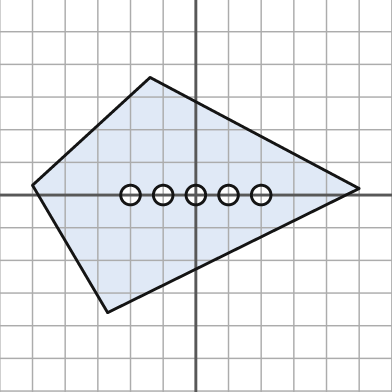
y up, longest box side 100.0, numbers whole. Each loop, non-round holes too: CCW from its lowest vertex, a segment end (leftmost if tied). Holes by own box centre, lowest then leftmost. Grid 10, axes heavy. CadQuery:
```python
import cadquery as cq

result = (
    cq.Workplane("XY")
    .moveTo(-27.0, -36.0)
    .lineTo(50.0, 2.0)
    .lineTo(-14.0, 36.0)
    .lineTo(-50.0, 3.0)
    .close()
    .moveTo(-20.0, 0.0)
    .circle(3.0)
    .moveTo(-10.0, 0.0)
    .circle(3.0)
    .moveTo(0.0, 0.0)
    .circle(3.0)
    .moveTo(10.0, 0.0)
    .circle(3.0)
    .moveTo(20.0, 0.0)
    .circle(3.0)
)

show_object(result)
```